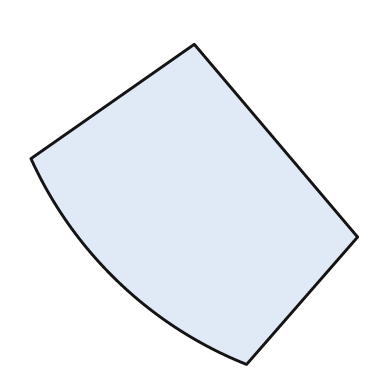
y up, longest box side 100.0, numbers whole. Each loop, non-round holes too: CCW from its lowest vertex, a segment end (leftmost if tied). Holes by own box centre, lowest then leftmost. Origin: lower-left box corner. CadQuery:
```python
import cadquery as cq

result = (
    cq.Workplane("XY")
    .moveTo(66.0, 0.0)
    .lineTo(100.0, 39.0)
    .lineTo(50.0, 98.0)
    .lineTo(0.0, 63.0)
    .threePointArc((27.0, 25.0), (66.0, 0.0))
    .close()
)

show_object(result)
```